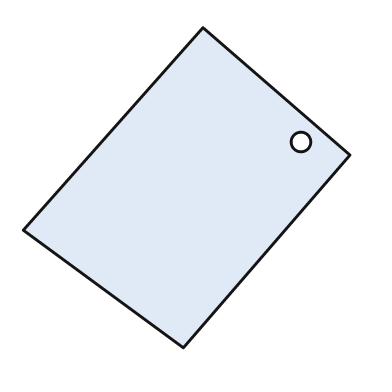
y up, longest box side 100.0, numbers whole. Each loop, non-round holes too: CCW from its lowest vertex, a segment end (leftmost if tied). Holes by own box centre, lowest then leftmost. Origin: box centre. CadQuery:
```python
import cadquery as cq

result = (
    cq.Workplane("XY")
    .moveTo(-1.0, -49.0)
    .lineTo(50.0, 10.0)
    .lineTo(5.0, 49.0)
    .lineTo(-50.0, -13.0)
    .close()
    .moveTo(35.0, 14.0)
    .circle(3.0)
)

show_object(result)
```